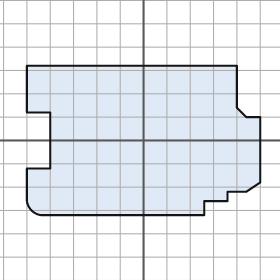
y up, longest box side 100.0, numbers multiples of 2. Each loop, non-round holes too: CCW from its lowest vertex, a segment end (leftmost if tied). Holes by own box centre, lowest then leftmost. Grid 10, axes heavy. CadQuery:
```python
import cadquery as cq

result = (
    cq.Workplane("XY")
    .moveTo(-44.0, -32.0)
    .lineTo(26.0, -32.0)
    .lineTo(26.0, -26.0)
    .lineTo(36.0, -26.0)
    .lineTo(36.0, -22.0)
    .lineTo(44.0, -22.0)
    .lineTo(50.0, -18.0)
    .lineTo(50.0, 10.0)
    .lineTo(44.0, 10.0)
    .lineTo(40.0, 14.0)
    .lineTo(40.0, 32.0)
    .lineTo(-50.0, 32.0)
    .lineTo(-50.0, 12.0)
    .lineTo(-40.0, 12.0)
    .lineTo(-40.0, -12.0)
    .lineTo(-50.0, -12.0)
    .lineTo(-50.0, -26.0)
    .threePointArc((-48.0, -30.0), (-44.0, -32.0))
    .close()
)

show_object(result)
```